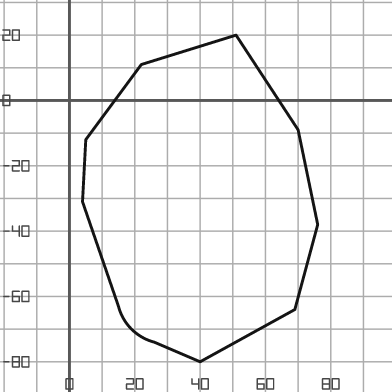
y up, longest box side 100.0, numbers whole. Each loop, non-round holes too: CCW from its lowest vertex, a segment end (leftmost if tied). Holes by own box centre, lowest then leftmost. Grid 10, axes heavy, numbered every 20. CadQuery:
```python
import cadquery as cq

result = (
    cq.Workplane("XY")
    .moveTo(40.0, -80.0)
    .lineTo(69.0, -64.0)
    .lineTo(76.0, -38.0)
    .lineTo(70.0, -9.0)
    .lineTo(51.0, 20.0)
    .lineTo(22.0, 11.0)
    .lineTo(5.0, -12.0)
    .lineTo(4.0, -31.0)
    .lineTo(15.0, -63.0)
    .threePointArc((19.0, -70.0), (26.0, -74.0))
    .close()
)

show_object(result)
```